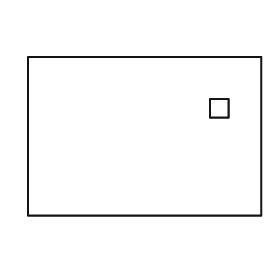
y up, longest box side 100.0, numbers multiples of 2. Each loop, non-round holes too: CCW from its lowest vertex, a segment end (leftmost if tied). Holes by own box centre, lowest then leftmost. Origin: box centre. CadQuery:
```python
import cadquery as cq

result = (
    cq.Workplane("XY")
    .moveTo(-50.0, -34.0)
    .lineTo(50.0, -34.0)
    .lineTo(50.0, 34.0)
    .lineTo(-50.0, 34.0)
    .close()
    .moveTo(28.0, 8.0)
    .lineTo(36.0, 8.0)
    .lineTo(36.0, 16.0)
    .lineTo(28.0, 16.0)
    .close()
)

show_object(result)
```